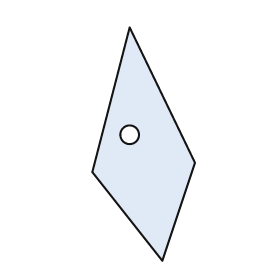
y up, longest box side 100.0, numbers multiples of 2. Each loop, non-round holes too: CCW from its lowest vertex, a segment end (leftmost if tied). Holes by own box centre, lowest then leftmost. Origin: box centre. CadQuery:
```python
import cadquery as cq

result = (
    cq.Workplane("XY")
    .moveTo(8.0, -50.0)
    .lineTo(22.0, -8.0)
    .lineTo(-6.0, 50.0)
    .lineTo(-22.0, -12.0)
    .close()
    .moveTo(-6.0, 4.0)
    .circle(4.0)
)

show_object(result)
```